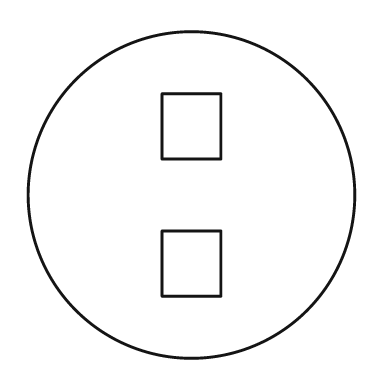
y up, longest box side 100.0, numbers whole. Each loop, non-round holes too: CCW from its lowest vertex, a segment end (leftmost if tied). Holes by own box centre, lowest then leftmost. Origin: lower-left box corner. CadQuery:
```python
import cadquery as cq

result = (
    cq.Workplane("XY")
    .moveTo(50.0, 50.0)
    .circle(50.0)
    .moveTo(41.0, 19.0)
    .lineTo(59.0, 19.0)
    .lineTo(59.0, 39.0)
    .lineTo(41.0, 39.0)
    .close()
    .moveTo(41.0, 61.0)
    .lineTo(59.0, 61.0)
    .lineTo(59.0, 81.0)
    .lineTo(41.0, 81.0)
    .close()
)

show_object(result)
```